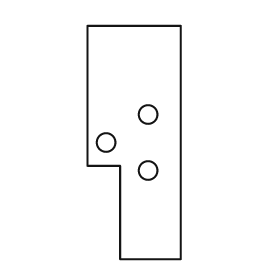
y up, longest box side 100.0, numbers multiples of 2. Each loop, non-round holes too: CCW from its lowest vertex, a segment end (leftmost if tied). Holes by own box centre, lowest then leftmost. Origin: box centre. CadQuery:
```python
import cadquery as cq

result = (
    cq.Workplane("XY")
    .moveTo(-6.0, -50.0)
    .lineTo(20.0, -50.0)
    .lineTo(20.0, 50.0)
    .lineTo(-20.0, 50.0)
    .lineTo(-20.0, -10.0)
    .lineTo(-6.0, -10.0)
    .close()
    .moveTo(6.0, -12.0)
    .circle(4.0)
    .moveTo(-12.0, 0.0)
    .circle(4.0)
    .moveTo(6.0, 12.0)
    .circle(4.0)
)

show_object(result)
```